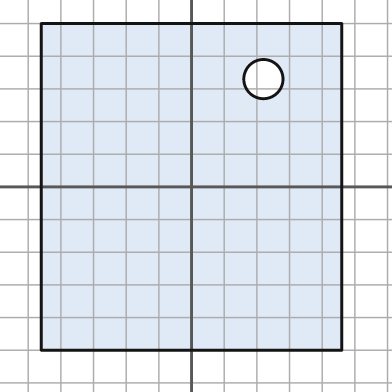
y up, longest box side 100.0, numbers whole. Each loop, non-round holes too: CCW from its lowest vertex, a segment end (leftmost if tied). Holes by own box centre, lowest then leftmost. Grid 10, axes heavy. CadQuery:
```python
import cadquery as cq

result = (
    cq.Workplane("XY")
    .moveTo(-46.0, -50.0)
    .lineTo(46.0, -50.0)
    .lineTo(46.0, 50.0)
    .lineTo(-46.0, 50.0)
    .close()
    .moveTo(22.0, 33.0)
    .circle(6.0)
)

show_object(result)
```